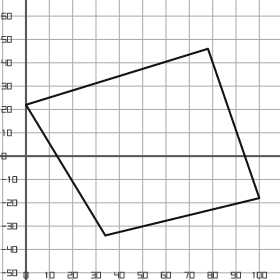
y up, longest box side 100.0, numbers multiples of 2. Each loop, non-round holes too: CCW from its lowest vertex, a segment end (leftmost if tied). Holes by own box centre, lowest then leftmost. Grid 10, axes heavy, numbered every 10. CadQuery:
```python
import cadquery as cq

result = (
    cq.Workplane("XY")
    .moveTo(34.0, -34.0)
    .lineTo(100.0, -18.0)
    .lineTo(78.0, 46.0)
    .lineTo(0.0, 22.0)
    .close()
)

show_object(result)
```